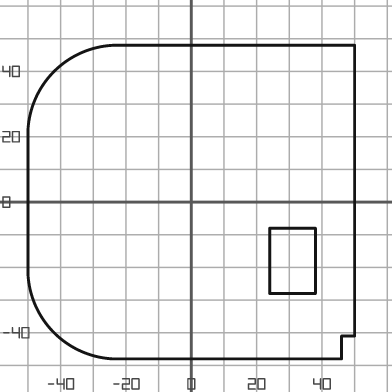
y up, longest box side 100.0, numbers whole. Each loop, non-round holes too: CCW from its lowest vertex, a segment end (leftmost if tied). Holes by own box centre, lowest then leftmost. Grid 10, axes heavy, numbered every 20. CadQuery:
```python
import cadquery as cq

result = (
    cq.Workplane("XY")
    .moveTo(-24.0, -48.0)
    .lineTo(46.0, -48.0)
    .lineTo(46.0, -41.0)
    .lineTo(50.0, -41.0)
    .lineTo(50.0, 48.0)
    .lineTo(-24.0, 48.0)
    .threePointArc((-42.0, 40.0), (-50.0, 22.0))
    .lineTo(-50.0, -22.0)
    .threePointArc((-42.0, -40.0), (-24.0, -48.0))
    .close()
    .moveTo(24.0, -28.0)
    .lineTo(38.0, -28.0)
    .lineTo(38.0, -8.0)
    .lineTo(24.0, -8.0)
    .close()
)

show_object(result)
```